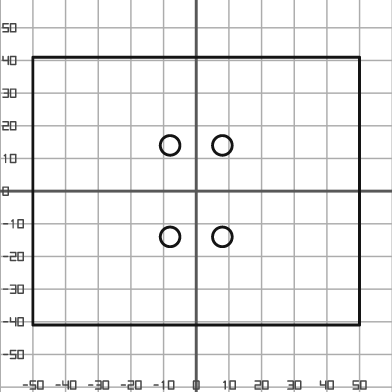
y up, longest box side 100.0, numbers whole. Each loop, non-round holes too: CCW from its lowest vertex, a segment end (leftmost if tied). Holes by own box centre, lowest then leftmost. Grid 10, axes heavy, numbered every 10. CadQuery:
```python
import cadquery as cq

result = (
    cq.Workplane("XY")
    .moveTo(-50.0, -41.0)
    .lineTo(50.0, -41.0)
    .lineTo(50.0, 41.0)
    .lineTo(-50.0, 41.0)
    .close()
    .moveTo(-8.0, -14.0)
    .circle(3.0)
    .moveTo(8.0, -14.0)
    .circle(3.0)
    .moveTo(-8.0, 14.0)
    .circle(3.0)
    .moveTo(8.0, 14.0)
    .circle(3.0)
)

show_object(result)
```